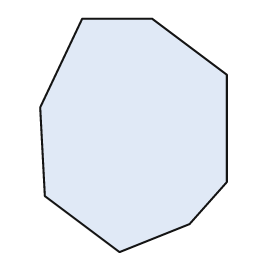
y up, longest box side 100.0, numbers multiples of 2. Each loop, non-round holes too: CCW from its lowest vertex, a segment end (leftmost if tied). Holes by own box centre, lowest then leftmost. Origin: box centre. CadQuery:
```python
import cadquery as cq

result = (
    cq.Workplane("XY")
    .moveTo(-6.0, -50.0)
    .lineTo(24.0, -38.0)
    .lineTo(40.0, -20.0)
    .lineTo(40.0, 26.0)
    .lineTo(8.0, 50.0)
    .lineTo(-22.0, 50.0)
    .lineTo(-40.0, 12.0)
    .lineTo(-38.0, -26.0)
    .close()
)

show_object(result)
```